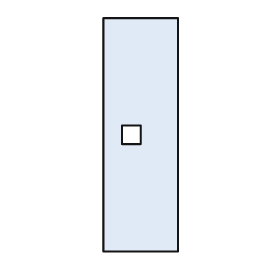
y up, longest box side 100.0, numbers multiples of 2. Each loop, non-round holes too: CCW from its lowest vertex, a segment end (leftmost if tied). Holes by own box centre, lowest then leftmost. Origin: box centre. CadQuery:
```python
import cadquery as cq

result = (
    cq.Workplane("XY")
    .moveTo(-16.0, -50.0)
    .lineTo(16.0, -50.0)
    .lineTo(16.0, 50.0)
    .lineTo(-16.0, 50.0)
    .close()
    .moveTo(-8.0, -4.0)
    .lineTo(0.0, -4.0)
    .lineTo(0.0, 4.0)
    .lineTo(-8.0, 4.0)
    .close()
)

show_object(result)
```